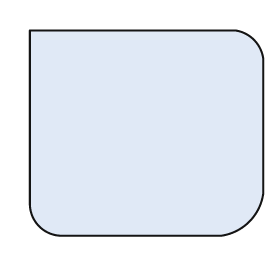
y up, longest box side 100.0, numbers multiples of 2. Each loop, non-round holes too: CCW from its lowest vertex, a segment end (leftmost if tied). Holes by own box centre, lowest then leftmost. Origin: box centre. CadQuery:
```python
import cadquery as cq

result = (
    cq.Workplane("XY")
    .moveTo(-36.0, -44.0)
    .lineTo(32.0, -44.0)
    .threePointArc((44.0, -38.0), (50.0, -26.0))
    .lineTo(50.0, 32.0)
    .threePointArc((46.0, 40.0), (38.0, 44.0))
    .lineTo(-50.0, 44.0)
    .lineTo(-50.0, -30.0)
    .threePointArc((-46.0, -40.0), (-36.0, -44.0))
    .close()
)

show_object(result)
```